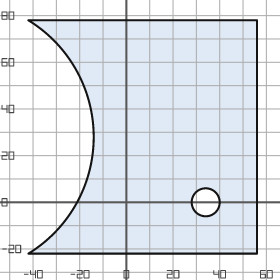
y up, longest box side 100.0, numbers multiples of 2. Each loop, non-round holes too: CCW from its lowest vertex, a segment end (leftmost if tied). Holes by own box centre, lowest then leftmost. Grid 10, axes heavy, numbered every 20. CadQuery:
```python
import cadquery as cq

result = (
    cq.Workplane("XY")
    .moveTo(-42.0, -22.0)
    .lineTo(56.0, -22.0)
    .lineTo(56.0, 78.0)
    .lineTo(-42.0, 78.0)
    .threePointArc((-14.0, 28.0), (-42.0, -22.0))
    .close()
    .moveTo(34.0, 0.0)
    .circle(6.0)
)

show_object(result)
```